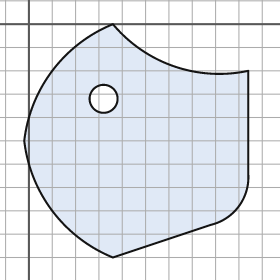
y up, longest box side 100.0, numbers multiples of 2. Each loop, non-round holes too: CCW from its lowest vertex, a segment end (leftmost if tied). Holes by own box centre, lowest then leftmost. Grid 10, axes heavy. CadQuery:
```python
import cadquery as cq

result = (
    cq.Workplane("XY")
    .moveTo(36.0, -100.0)
    .lineTo(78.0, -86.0)
    .threePointArc((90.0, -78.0), (94.0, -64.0))
    .lineTo(94.0, -20.0)
    .threePointArc((62.0, -18.0), (36.0, 0.0))
    .threePointArc((10.0, -20.0), (-2.0, -50.0))
    .threePointArc((10.0, -80.0), (36.0, -100.0))
    .close()
    .moveTo(32.0, -32.0)
    .circle(6.0)
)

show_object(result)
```